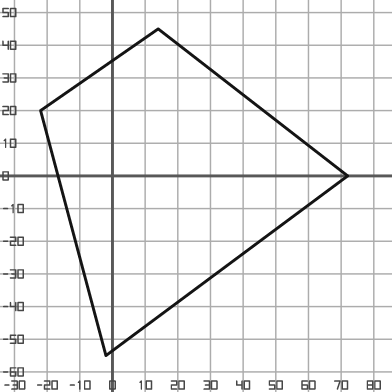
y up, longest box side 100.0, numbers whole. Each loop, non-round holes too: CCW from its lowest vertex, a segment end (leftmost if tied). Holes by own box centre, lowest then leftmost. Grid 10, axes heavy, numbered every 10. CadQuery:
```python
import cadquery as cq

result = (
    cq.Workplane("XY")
    .moveTo(-2.0, -55.0)
    .lineTo(72.0, 0.0)
    .lineTo(14.0, 45.0)
    .lineTo(-22.0, 20.0)
    .close()
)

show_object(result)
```